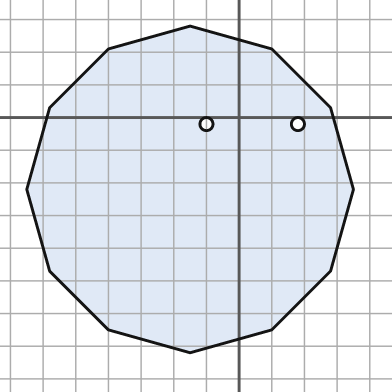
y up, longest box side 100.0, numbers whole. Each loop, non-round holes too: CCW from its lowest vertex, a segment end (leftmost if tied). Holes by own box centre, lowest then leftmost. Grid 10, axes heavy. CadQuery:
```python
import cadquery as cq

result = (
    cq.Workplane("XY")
    .moveTo(-15.0, -72.0)
    .lineTo(10.0, -65.0)
    .lineTo(28.0, -47.0)
    .lineTo(35.0, -22.0)
    .lineTo(28.0, 3.0)
    .lineTo(10.0, 21.0)
    .lineTo(-15.0, 28.0)
    .lineTo(-40.0, 21.0)
    .lineTo(-58.0, 3.0)
    .lineTo(-65.0, -22.0)
    .lineTo(-58.0, -47.0)
    .lineTo(-40.0, -65.0)
    .close()
    .moveTo(-10.0, -2.0)
    .circle(2.0)
    .moveTo(18.0, -2.0)
    .circle(2.0)
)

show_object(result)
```